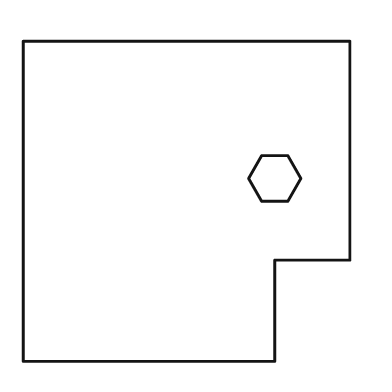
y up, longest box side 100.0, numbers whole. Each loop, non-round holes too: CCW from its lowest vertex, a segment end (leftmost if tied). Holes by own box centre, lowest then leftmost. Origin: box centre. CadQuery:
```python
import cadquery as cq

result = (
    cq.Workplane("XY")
    .moveTo(-50.0, -49.0)
    .lineTo(27.0, -49.0)
    .lineTo(27.0, -18.0)
    .lineTo(50.0, -18.0)
    .lineTo(50.0, 49.0)
    .lineTo(-50.0, 49.0)
    .close()
    .moveTo(23.0, 0.0)
    .lineTo(31.0, 0.0)
    .lineTo(35.0, 7.0)
    .lineTo(31.0, 14.0)
    .lineTo(23.0, 14.0)
    .lineTo(19.0, 7.0)
    .close()
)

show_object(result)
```